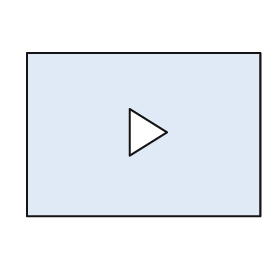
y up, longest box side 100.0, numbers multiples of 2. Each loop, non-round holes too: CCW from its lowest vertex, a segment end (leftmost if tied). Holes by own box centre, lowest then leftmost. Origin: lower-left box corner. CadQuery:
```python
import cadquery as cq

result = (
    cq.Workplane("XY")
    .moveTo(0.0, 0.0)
    .lineTo(100.0, 0.0)
    .lineTo(100.0, 70.0)
    .lineTo(0.0, 70.0)
    .close()
    .moveTo(44.0, 26.0)
    .lineTo(60.0, 36.0)
    .lineTo(44.0, 46.0)
    .close()
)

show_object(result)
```